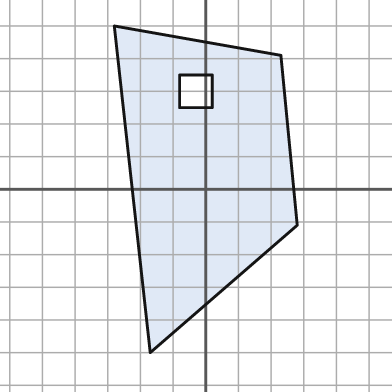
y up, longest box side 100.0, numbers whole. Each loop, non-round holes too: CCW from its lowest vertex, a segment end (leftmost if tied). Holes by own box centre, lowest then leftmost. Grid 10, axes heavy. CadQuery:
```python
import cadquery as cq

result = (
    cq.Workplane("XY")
    .moveTo(-17.0, -50.0)
    .lineTo(28.0, -11.0)
    .lineTo(23.0, 41.0)
    .lineTo(-28.0, 50.0)
    .close()
    .moveTo(-8.0, 25.0)
    .lineTo(2.0, 25.0)
    .lineTo(2.0, 35.0)
    .lineTo(-8.0, 35.0)
    .close()
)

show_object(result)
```